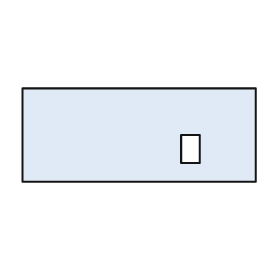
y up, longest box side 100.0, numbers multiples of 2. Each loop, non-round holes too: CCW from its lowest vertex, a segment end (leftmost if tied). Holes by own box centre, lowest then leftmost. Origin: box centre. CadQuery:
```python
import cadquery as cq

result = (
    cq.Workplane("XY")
    .moveTo(-50.0, -20.0)
    .lineTo(50.0, -20.0)
    .lineTo(50.0, 20.0)
    .lineTo(-50.0, 20.0)
    .close()
    .moveTo(18.0, -12.0)
    .lineTo(26.0, -12.0)
    .lineTo(26.0, 0.0)
    .lineTo(18.0, 0.0)
    .close()
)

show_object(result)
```